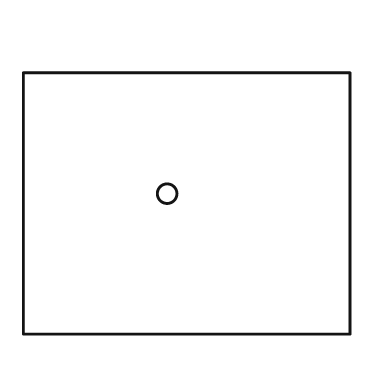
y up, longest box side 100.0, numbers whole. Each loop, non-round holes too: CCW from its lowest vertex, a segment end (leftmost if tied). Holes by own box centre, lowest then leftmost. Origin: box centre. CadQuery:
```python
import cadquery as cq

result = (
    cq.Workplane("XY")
    .moveTo(-50.0, -40.0)
    .lineTo(50.0, -40.0)
    .lineTo(50.0, 40.0)
    .lineTo(-50.0, 40.0)
    .close()
    .moveTo(-6.0, 3.0)
    .circle(3.0)
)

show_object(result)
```